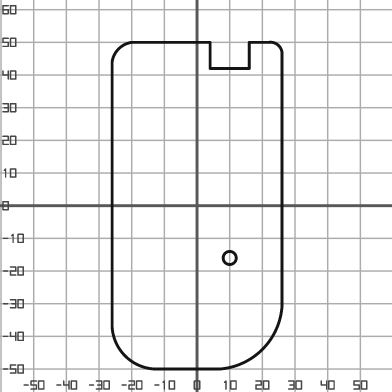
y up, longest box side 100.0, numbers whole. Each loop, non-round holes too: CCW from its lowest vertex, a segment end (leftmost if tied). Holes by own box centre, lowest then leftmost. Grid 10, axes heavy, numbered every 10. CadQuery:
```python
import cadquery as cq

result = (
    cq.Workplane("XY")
    .moveTo(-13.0, -50.0)
    .lineTo(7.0, -50.0)
    .threePointArc((20.0, -44.0), (26.0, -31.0))
    .lineTo(26.0, 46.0)
    .threePointArc((25.0, 49.0), (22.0, 50.0))
    .lineTo(16.0, 50.0)
    .lineTo(16.0, 42.0)
    .lineTo(4.0, 42.0)
    .lineTo(4.0, 50.0)
    .lineTo(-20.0, 50.0)
    .threePointArc((-24.0, 48.0), (-26.0, 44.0))
    .lineTo(-26.0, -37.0)
    .threePointArc((-22.0, -46.0), (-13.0, -50.0))
    .close()
    .moveTo(10.0, -16.0)
    .circle(2.0)
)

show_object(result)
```